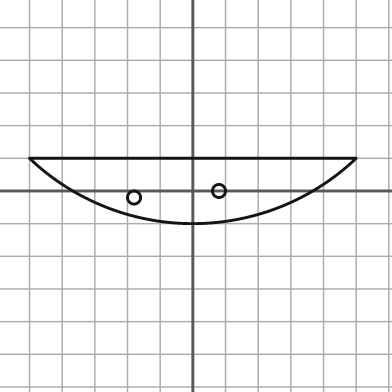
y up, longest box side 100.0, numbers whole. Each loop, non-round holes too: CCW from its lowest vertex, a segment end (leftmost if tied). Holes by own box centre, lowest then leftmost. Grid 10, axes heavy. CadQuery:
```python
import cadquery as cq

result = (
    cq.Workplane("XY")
    .moveTo(-50.0, 10.0)
    .threePointArc((0.0, -10.0), (50.0, 10.0))
    .close()
    .moveTo(-18.0, -2.0)
    .circle(2.0)
    .moveTo(8.0, 0.0)
    .circle(2.0)
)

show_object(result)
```